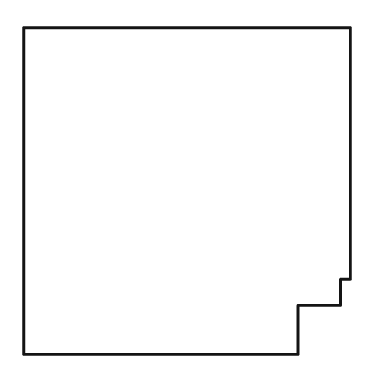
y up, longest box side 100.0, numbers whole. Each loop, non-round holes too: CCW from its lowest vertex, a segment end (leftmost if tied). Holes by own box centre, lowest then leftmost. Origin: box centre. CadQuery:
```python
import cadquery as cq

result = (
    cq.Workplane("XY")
    .moveTo(-50.0, -50.0)
    .lineTo(34.0, -50.0)
    .lineTo(34.0, -35.0)
    .lineTo(47.0, -35.0)
    .lineTo(47.0, -27.0)
    .lineTo(50.0, -27.0)
    .lineTo(50.0, 50.0)
    .lineTo(-50.0, 50.0)
    .close()
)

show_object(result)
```